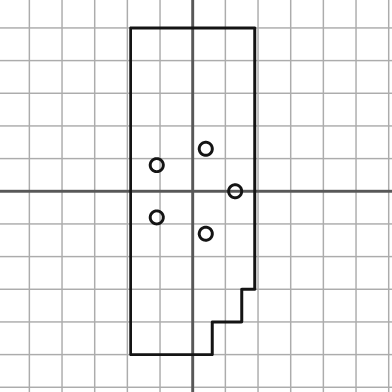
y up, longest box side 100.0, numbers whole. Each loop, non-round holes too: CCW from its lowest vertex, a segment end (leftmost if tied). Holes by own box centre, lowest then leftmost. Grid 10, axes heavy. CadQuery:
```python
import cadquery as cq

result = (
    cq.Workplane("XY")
    .moveTo(-19.0, -50.0)
    .lineTo(6.0, -50.0)
    .lineTo(6.0, -40.0)
    .lineTo(15.0, -40.0)
    .lineTo(15.0, -30.0)
    .lineTo(19.0, -30.0)
    .lineTo(19.0, 50.0)
    .lineTo(-19.0, 50.0)
    .close()
    .moveTo(4.0, -13.0)
    .circle(2.0)
    .moveTo(-11.0, -8.0)
    .circle(2.0)
    .moveTo(13.0, 0.0)
    .circle(2.0)
    .moveTo(-11.0, 8.0)
    .circle(2.0)
    .moveTo(4.0, 13.0)
    .circle(2.0)
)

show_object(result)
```